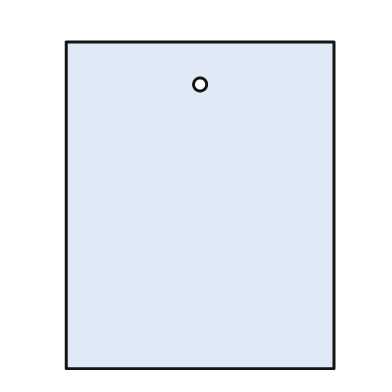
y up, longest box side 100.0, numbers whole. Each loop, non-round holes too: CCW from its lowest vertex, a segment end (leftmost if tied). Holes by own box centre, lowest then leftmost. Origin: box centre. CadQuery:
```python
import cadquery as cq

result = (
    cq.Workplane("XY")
    .moveTo(-41.0, -50.0)
    .lineTo(41.0, -50.0)
    .lineTo(41.0, 50.0)
    .lineTo(-41.0, 50.0)
    .close()
    .moveTo(0.0, 37.0)
    .circle(2.0)
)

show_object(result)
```